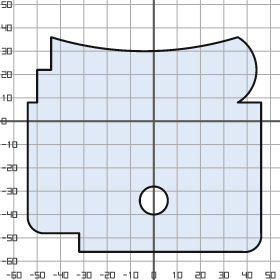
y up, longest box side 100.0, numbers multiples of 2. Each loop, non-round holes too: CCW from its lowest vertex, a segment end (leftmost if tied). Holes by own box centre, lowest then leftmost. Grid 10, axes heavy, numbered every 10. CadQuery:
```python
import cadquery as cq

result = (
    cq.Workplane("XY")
    .moveTo(-32.0, -56.0)
    .lineTo(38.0, -56.0)
    .threePointArc((44.0, -54.0), (46.0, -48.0))
    .lineTo(46.0, 8.0)
    .lineTo(36.0, 8.0)
    .threePointArc((44.0, 22.0), (36.0, 36.0))
    .threePointArc((-4.0, 30.0), (-44.0, 36.0))
    .lineTo(-44.0, 22.0)
    .lineTo(-50.0, 22.0)
    .lineTo(-50.0, 8.0)
    .lineTo(-54.0, 8.0)
    .lineTo(-54.0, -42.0)
    .threePointArc((-52.0, -46.0), (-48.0, -48.0))
    .lineTo(-32.0, -48.0)
    .close()
    .moveTo(0.0, -34.0)
    .circle(6.0)
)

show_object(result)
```